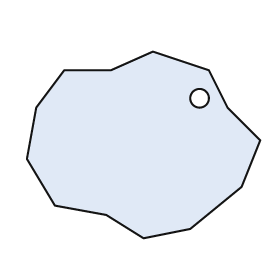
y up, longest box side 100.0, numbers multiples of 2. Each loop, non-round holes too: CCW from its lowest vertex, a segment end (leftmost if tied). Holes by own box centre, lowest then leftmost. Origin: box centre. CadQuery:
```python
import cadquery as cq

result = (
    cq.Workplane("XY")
    .moveTo(0.0, -40.0)
    .lineTo(20.0, -36.0)
    .lineTo(42.0, -18.0)
    .lineTo(50.0, 2.0)
    .lineTo(36.0, 16.0)
    .lineTo(28.0, 32.0)
    .lineTo(4.0, 40.0)
    .lineTo(-14.0, 32.0)
    .lineTo(-34.0, 32.0)
    .lineTo(-46.0, 16.0)
    .lineTo(-50.0, -6.0)
    .lineTo(-38.0, -26.0)
    .lineTo(-16.0, -30.0)
    .close()
    .moveTo(24.0, 20.0)
    .circle(4.0)
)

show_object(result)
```